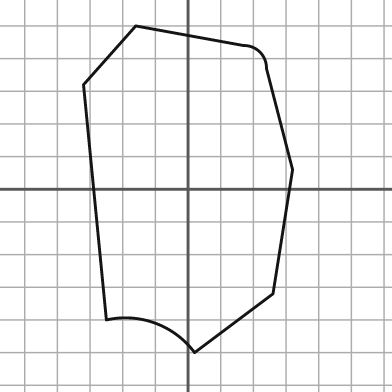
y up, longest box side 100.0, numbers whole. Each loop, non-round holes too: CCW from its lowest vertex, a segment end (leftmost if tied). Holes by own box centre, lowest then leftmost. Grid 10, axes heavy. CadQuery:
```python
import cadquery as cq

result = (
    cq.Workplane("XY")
    .moveTo(2.0, -50.0)
    .lineTo(26.0, -32.0)
    .lineTo(32.0, 6.0)
    .lineTo(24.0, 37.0)
    .threePointArc((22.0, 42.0), (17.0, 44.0))
    .lineTo(-16.0, 50.0)
    .lineTo(-32.0, 32.0)
    .lineTo(-25.0, -40.0)
    .threePointArc((-10.0, -41.0), (2.0, -50.0))
    .close()
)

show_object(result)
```